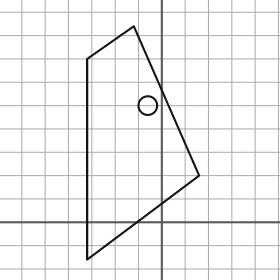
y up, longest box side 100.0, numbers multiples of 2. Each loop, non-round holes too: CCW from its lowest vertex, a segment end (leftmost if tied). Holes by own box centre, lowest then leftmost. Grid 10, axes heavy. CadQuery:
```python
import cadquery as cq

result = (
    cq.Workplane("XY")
    .moveTo(-32.0, -16.0)
    .lineTo(16.0, 20.0)
    .lineTo(-12.0, 84.0)
    .lineTo(-32.0, 70.0)
    .close()
    .moveTo(-6.0, 50.0)
    .circle(4.0)
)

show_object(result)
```